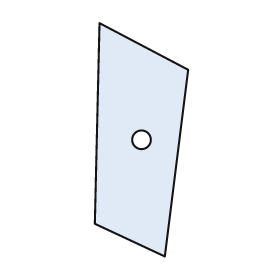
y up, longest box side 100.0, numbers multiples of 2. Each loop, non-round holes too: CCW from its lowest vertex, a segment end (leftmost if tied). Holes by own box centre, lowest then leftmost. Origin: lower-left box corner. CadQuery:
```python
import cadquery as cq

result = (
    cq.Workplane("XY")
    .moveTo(30.0, 0.0)
    .lineTo(40.0, 80.0)
    .lineTo(2.0, 100.0)
    .lineTo(0.0, 14.0)
    .close()
    .moveTo(20.0, 50.0)
    .circle(4.0)
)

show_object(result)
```